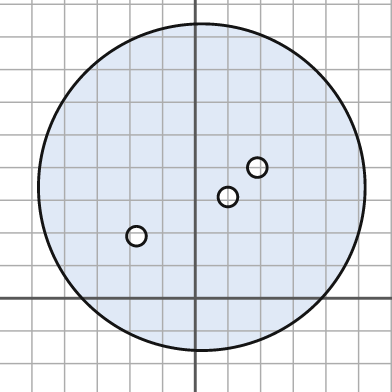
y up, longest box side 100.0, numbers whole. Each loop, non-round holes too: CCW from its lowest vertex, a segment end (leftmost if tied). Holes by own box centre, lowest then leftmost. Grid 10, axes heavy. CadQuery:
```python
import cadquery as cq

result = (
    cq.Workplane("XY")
    .moveTo(2.0, 34.0)
    .circle(50.0)
    .moveTo(-18.0, 19.0)
    .circle(3.0)
    .moveTo(10.0, 31.0)
    .circle(3.0)
    .moveTo(19.0, 40.0)
    .circle(3.0)
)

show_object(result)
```